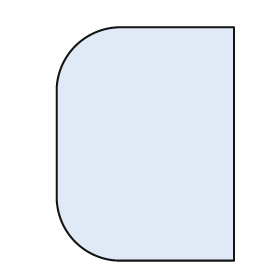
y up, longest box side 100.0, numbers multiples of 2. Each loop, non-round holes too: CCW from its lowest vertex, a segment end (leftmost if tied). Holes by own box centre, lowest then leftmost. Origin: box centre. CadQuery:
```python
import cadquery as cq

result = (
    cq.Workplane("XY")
    .moveTo(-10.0, -50.0)
    .lineTo(38.0, -50.0)
    .lineTo(38.0, 50.0)
    .lineTo(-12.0, 50.0)
    .threePointArc((-30.0, 42.0), (-38.0, 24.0))
    .lineTo(-38.0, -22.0)
    .threePointArc((-30.0, -42.0), (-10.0, -50.0))
    .close()
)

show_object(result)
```